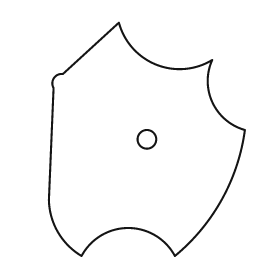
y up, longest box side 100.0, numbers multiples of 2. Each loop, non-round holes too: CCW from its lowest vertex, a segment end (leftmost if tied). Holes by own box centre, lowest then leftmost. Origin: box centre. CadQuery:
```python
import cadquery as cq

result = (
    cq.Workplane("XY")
    .moveTo(-28.0, -50.0)
    .threePointArc((-8.0, -38.0), (12.0, -50.0))
    .threePointArc((32.0, -26.0), (42.0, 4.0))
    .threePointArc((28.0, 16.0), (28.0, 34.0))
    .threePointArc((4.0, 32.0), (-12.0, 50.0))
    .lineTo(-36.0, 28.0)
    .threePointArc((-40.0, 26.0), (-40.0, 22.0))
    .lineTo(-42.0, -26.0)
    .threePointArc((-38.0, -40.0), (-28.0, -50.0))
    .close()
    .moveTo(0.0, 0.0)
    .circle(4.0)
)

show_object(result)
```